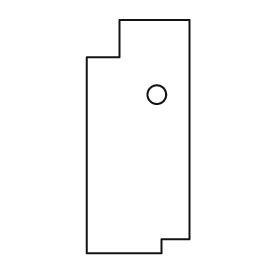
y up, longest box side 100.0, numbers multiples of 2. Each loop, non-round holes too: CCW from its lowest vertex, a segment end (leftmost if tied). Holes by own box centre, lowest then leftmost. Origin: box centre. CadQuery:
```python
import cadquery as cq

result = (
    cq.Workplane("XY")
    .moveTo(-22.0, -50.0)
    .lineTo(10.0, -50.0)
    .lineTo(10.0, -44.0)
    .lineTo(22.0, -44.0)
    .lineTo(22.0, 50.0)
    .lineTo(-8.0, 50.0)
    .lineTo(-8.0, 34.0)
    .lineTo(-22.0, 34.0)
    .close()
    .moveTo(8.0, 18.0)
    .circle(4.0)
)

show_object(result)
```